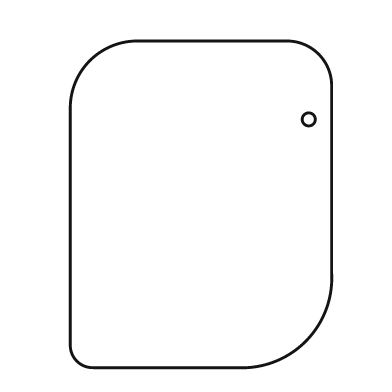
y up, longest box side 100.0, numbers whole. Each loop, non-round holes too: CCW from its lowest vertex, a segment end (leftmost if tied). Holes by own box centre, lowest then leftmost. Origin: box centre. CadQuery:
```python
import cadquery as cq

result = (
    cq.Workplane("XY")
    .moveTo(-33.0, -50.0)
    .lineTo(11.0, -50.0)
    .threePointArc((32.0, -42.0), (40.0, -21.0))
    .lineTo(40.0, 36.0)
    .threePointArc((36.0, 46.0), (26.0, 50.0))
    .lineTo(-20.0, 50.0)
    .threePointArc((-34.0, 44.0), (-40.0, 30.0))
    .lineTo(-40.0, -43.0)
    .threePointArc((-38.0, -48.0), (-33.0, -50.0))
    .close()
    .moveTo(33.0, 26.0)
    .circle(2.0)
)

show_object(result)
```